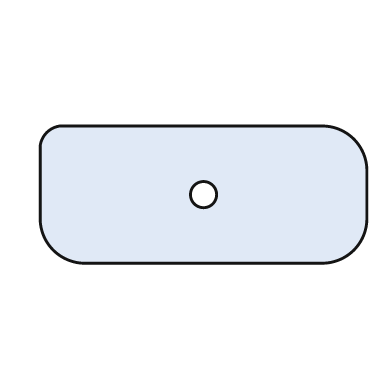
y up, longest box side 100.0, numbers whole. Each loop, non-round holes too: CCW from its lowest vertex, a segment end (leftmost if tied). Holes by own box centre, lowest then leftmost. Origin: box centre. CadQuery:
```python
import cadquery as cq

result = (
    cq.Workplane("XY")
    .moveTo(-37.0, -21.0)
    .lineTo(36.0, -21.0)
    .threePointArc((46.0, -17.0), (50.0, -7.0))
    .lineTo(50.0, 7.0)
    .threePointArc((46.0, 17.0), (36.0, 21.0))
    .lineTo(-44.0, 21.0)
    .threePointArc((-48.0, 19.0), (-50.0, 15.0))
    .lineTo(-50.0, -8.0)
    .threePointArc((-46.0, -17.0), (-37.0, -21.0))
    .close()
    .moveTo(0.0, 0.0)
    .circle(4.0)
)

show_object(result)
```